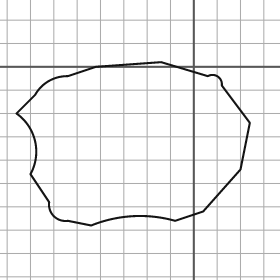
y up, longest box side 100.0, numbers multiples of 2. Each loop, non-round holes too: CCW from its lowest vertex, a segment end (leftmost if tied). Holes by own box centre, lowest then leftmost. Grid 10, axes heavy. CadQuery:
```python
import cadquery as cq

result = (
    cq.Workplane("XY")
    .moveTo(-44.0, -68.0)
    .threePointArc((-26.0, -64.0), (-8.0, -66.0))
    .lineTo(4.0, -62.0)
    .lineTo(20.0, -44.0)
    .lineTo(24.0, -24.0)
    .lineTo(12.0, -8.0)
    .threePointArc((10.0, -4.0), (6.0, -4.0))
    .lineTo(-14.0, 2.0)
    .lineTo(-42.0, 0.0)
    .lineTo(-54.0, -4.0)
    .threePointArc((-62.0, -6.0), (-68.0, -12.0))
    .lineTo(-76.0, -20.0)
    .threePointArc((-68.0, -32.0), (-70.0, -46.0))
    .lineTo(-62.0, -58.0)
    .threePointArc((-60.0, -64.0), (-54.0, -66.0))
    .close()
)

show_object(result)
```